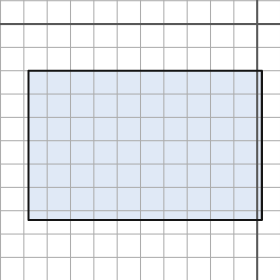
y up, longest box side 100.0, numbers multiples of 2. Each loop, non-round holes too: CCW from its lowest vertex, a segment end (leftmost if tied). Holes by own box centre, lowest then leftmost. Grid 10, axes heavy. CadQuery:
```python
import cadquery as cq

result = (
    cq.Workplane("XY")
    .moveTo(-98.0, -84.0)
    .lineTo(2.0, -84.0)
    .lineTo(2.0, -20.0)
    .lineTo(-98.0, -20.0)
    .close()
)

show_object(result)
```